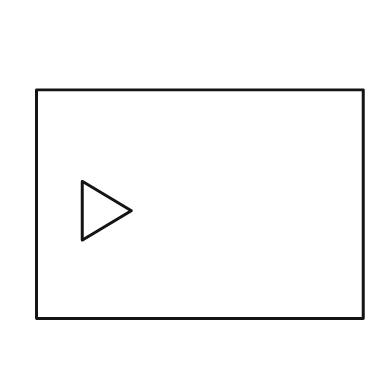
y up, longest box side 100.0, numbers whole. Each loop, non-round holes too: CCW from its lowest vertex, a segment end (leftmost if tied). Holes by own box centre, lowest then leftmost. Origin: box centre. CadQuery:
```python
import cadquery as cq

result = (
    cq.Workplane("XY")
    .moveTo(-50.0, -35.0)
    .lineTo(50.0, -35.0)
    .lineTo(50.0, 35.0)
    .lineTo(-50.0, 35.0)
    .close()
    .moveTo(-36.0, -11.0)
    .lineTo(-21.0, -2.0)
    .lineTo(-36.0, 7.0)
    .close()
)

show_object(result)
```